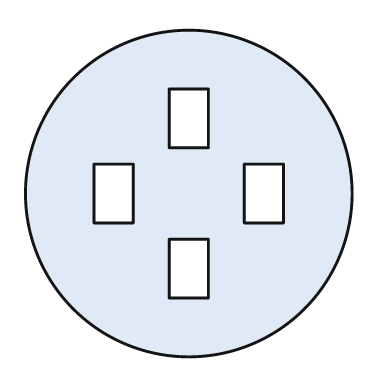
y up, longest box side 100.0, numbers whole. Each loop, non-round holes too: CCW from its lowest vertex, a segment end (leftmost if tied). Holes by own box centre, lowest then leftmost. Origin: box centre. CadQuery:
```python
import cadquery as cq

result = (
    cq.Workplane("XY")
    .moveTo(0.0, 0.0)
    .circle(50.0)
    .moveTo(-6.0, -32.0)
    .lineTo(6.0, -32.0)
    .lineTo(6.0, -14.0)
    .lineTo(-6.0, -14.0)
    .close()
    .moveTo(-29.0, -9.0)
    .lineTo(-17.0, -9.0)
    .lineTo(-17.0, 9.0)
    .lineTo(-29.0, 9.0)
    .close()
    .moveTo(17.0, -9.0)
    .lineTo(29.0, -9.0)
    .lineTo(29.0, 9.0)
    .lineTo(17.0, 9.0)
    .close()
    .moveTo(-6.0, 14.0)
    .lineTo(6.0, 14.0)
    .lineTo(6.0, 32.0)
    .lineTo(-6.0, 32.0)
    .close()
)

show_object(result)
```